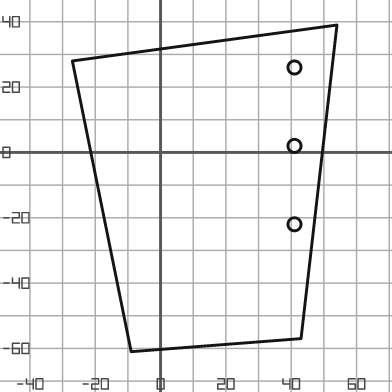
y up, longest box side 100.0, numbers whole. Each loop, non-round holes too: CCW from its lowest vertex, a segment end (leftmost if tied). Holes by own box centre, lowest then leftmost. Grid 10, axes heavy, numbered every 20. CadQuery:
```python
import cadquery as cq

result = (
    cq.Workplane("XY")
    .moveTo(-9.0, -61.0)
    .lineTo(43.0, -57.0)
    .lineTo(54.0, 39.0)
    .lineTo(-27.0, 28.0)
    .close()
    .moveTo(41.0, -22.0)
    .circle(2.0)
    .moveTo(41.0, 2.0)
    .circle(2.0)
    .moveTo(41.0, 26.0)
    .circle(2.0)
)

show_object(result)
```